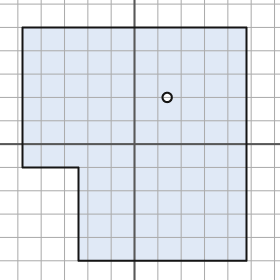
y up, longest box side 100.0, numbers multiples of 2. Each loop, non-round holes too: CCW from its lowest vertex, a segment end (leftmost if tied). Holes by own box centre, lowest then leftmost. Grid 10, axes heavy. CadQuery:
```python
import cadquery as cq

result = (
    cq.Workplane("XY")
    .moveTo(-24.0, -50.0)
    .lineTo(48.0, -50.0)
    .lineTo(48.0, 50.0)
    .lineTo(-48.0, 50.0)
    .lineTo(-48.0, -10.0)
    .lineTo(-24.0, -10.0)
    .close()
    .moveTo(14.0, 20.0)
    .circle(2.0)
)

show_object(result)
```